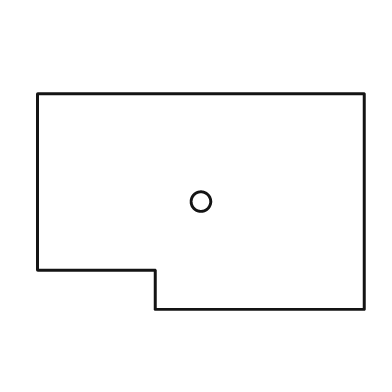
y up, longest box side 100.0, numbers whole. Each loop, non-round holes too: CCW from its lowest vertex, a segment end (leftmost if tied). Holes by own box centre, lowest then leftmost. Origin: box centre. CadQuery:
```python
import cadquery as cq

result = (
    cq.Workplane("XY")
    .moveTo(-14.0, -33.0)
    .lineTo(50.0, -33.0)
    .lineTo(50.0, 33.0)
    .lineTo(-50.0, 33.0)
    .lineTo(-50.0, -21.0)
    .lineTo(-14.0, -21.0)
    .close()
    .moveTo(0.0, 0.0)
    .circle(3.0)
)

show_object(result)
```